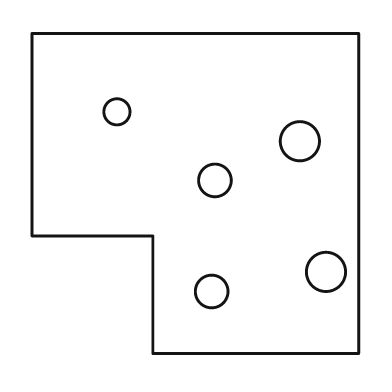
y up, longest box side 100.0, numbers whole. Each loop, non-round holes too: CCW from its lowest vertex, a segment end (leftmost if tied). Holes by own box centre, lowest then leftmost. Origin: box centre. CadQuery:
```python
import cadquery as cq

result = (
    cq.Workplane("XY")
    .moveTo(-13.0, -49.0)
    .lineTo(50.0, -49.0)
    .lineTo(50.0, 49.0)
    .lineTo(-50.0, 49.0)
    .lineTo(-50.0, -13.0)
    .lineTo(-13.0, -13.0)
    .close()
    .moveTo(5.0, -30.0)
    .circle(5.0)
    .moveTo(40.0, -24.0)
    .circle(6.0)
    .moveTo(6.0, 4.0)
    .circle(5.0)
    .moveTo(32.0, 16.0)
    .circle(6.0)
    .moveTo(-24.0, 25.0)
    .circle(4.0)
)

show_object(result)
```